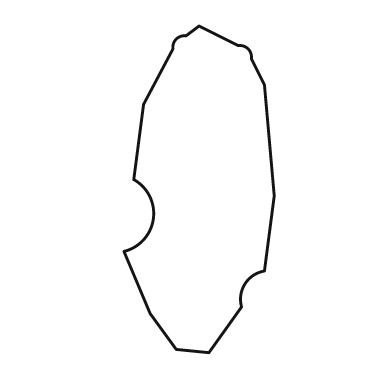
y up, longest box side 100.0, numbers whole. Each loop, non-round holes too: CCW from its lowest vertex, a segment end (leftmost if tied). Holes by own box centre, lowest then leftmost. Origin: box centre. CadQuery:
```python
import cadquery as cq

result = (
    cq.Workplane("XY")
    .moveTo(3.0, -50.0)
    .lineTo(13.0, -36.0)
    .threePointArc((14.0, -29.0), (20.0, -25.0))
    .lineTo(23.0, -2.0)
    .lineTo(20.0, 32.0)
    .lineTo(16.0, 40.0)
    .threePointArc((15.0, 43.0), (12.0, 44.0))
    .lineTo(0.0, 50.0)
    .lineTo(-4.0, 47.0)
    .threePointArc((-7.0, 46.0), (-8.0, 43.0))
    .lineTo(-17.0, 26.0)
    .lineTo(-20.0, 3.0)
    .threePointArc((-14.0, -9.0), (-23.0, -19.0))
    .lineTo(-15.0, -38.0)
    .lineTo(-7.0, -49.0)
    .close()
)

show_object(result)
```